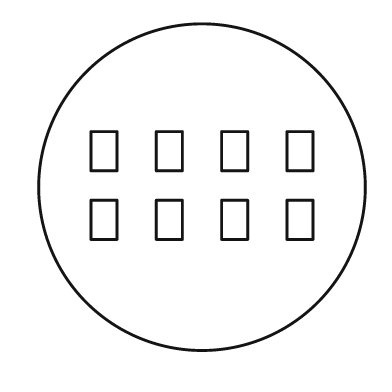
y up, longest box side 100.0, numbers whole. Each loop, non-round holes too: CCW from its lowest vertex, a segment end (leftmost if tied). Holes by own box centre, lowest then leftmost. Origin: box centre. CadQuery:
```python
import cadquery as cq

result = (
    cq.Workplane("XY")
    .moveTo(0.0, 0.0)
    .circle(50.0)
    .moveTo(-34.0, -16.0)
    .lineTo(-26.0, -16.0)
    .lineTo(-26.0, -4.0)
    .lineTo(-34.0, -4.0)
    .close()
    .moveTo(-14.0, -16.0)
    .lineTo(-6.0, -16.0)
    .lineTo(-6.0, -4.0)
    .lineTo(-14.0, -4.0)
    .close()
    .moveTo(6.0, -16.0)
    .lineTo(14.0, -16.0)
    .lineTo(14.0, -4.0)
    .lineTo(6.0, -4.0)
    .close()
    .moveTo(26.0, -16.0)
    .lineTo(34.0, -16.0)
    .lineTo(34.0, -4.0)
    .lineTo(26.0, -4.0)
    .close()
    .moveTo(-34.0, 5.0)
    .lineTo(-26.0, 5.0)
    .lineTo(-26.0, 17.0)
    .lineTo(-34.0, 17.0)
    .close()
    .moveTo(-14.0, 5.0)
    .lineTo(-6.0, 5.0)
    .lineTo(-6.0, 17.0)
    .lineTo(-14.0, 17.0)
    .close()
    .moveTo(6.0, 5.0)
    .lineTo(14.0, 5.0)
    .lineTo(14.0, 17.0)
    .lineTo(6.0, 17.0)
    .close()
    .moveTo(26.0, 5.0)
    .lineTo(34.0, 5.0)
    .lineTo(34.0, 17.0)
    .lineTo(26.0, 17.0)
    .close()
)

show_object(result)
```